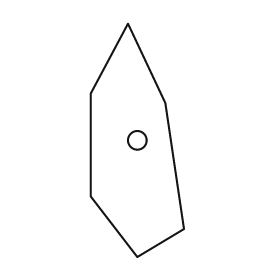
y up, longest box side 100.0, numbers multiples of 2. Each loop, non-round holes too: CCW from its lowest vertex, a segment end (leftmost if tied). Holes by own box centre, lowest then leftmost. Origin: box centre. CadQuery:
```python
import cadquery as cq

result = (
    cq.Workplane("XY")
    .moveTo(0.0, -50.0)
    .lineTo(20.0, -38.0)
    .lineTo(12.0, 16.0)
    .lineTo(-4.0, 50.0)
    .lineTo(-20.0, 20.0)
    .lineTo(-20.0, -24.0)
    .close()
    .moveTo(0.0, 0.0)
    .circle(4.0)
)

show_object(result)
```